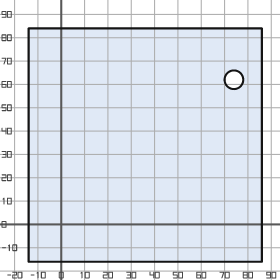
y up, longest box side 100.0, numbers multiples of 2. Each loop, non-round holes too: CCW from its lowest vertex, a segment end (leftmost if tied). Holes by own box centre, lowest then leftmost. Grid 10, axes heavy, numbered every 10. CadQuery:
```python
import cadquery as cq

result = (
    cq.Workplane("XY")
    .moveTo(-14.0, -16.0)
    .lineTo(86.0, -16.0)
    .lineTo(86.0, 84.0)
    .lineTo(-14.0, 84.0)
    .close()
    .moveTo(74.0, 62.0)
    .circle(4.0)
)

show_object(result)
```